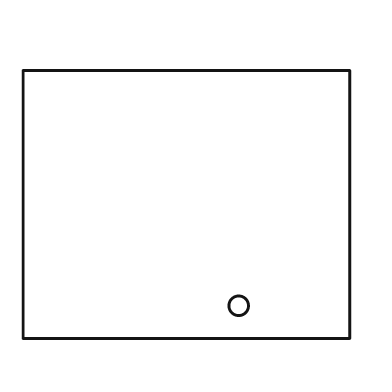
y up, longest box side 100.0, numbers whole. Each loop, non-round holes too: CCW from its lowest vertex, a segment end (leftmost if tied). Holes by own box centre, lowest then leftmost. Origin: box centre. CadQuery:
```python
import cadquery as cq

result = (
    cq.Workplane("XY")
    .moveTo(-50.0, -41.0)
    .lineTo(50.0, -41.0)
    .lineTo(50.0, 41.0)
    .lineTo(-50.0, 41.0)
    .close()
    .moveTo(16.0, -31.0)
    .circle(3.0)
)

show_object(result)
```